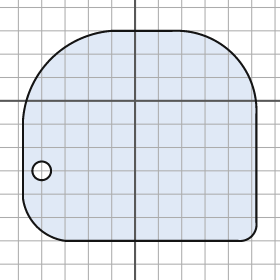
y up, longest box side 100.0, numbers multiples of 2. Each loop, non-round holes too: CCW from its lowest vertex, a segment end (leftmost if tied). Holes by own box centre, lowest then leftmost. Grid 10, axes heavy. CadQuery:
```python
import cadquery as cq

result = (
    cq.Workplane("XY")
    .moveTo(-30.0, -60.0)
    .lineTo(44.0, -60.0)
    .threePointArc((50.0, -58.0), (52.0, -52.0))
    .lineTo(52.0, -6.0)
    .threePointArc((42.0, 20.0), (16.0, 30.0))
    .lineTo(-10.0, 30.0)
    .threePointArc((-36.0, 18.0), (-48.0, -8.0))
    .lineTo(-48.0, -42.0)
    .threePointArc((-42.0, -54.0), (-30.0, -60.0))
    .close()
    .moveTo(-40.0, -30.0)
    .circle(4.0)
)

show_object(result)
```